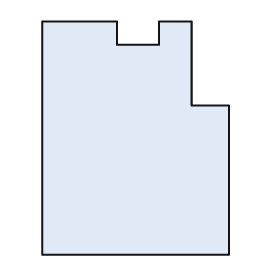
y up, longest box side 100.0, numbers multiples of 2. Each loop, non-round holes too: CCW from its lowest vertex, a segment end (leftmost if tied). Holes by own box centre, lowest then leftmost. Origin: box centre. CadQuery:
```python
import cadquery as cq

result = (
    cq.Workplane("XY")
    .moveTo(-40.0, -50.0)
    .lineTo(40.0, -50.0)
    .lineTo(40.0, 14.0)
    .lineTo(24.0, 14.0)
    .lineTo(24.0, 50.0)
    .lineTo(10.0, 50.0)
    .lineTo(10.0, 40.0)
    .lineTo(-8.0, 40.0)
    .lineTo(-8.0, 50.0)
    .lineTo(-40.0, 50.0)
    .close()
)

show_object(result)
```